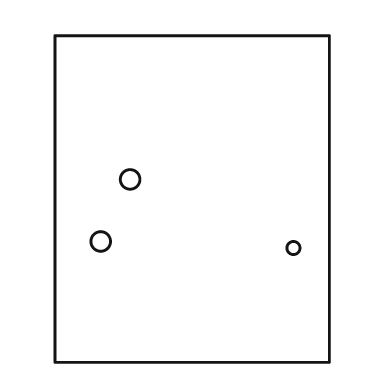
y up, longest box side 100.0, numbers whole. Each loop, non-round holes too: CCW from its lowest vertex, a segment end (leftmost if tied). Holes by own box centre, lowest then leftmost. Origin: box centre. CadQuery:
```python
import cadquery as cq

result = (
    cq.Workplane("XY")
    .moveTo(-42.0, -50.0)
    .lineTo(42.0, -50.0)
    .lineTo(42.0, 50.0)
    .lineTo(-42.0, 50.0)
    .close()
    .moveTo(31.0, -15.0)
    .circle(2.0)
    .moveTo(-28.0, -13.0)
    .circle(3.0)
    .moveTo(-19.0, 6.0)
    .circle(3.0)
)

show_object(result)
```